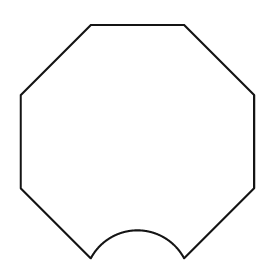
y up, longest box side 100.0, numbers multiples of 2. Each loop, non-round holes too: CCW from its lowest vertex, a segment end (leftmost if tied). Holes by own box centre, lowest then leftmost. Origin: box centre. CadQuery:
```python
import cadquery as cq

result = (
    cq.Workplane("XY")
    .moveTo(-20.0, -50.0)
    .threePointArc((0.0, -38.0), (20.0, -50.0))
    .lineTo(50.0, -20.0)
    .lineTo(50.0, 20.0)
    .lineTo(20.0, 50.0)
    .lineTo(-20.0, 50.0)
    .lineTo(-50.0, 20.0)
    .lineTo(-50.0, -20.0)
    .close()
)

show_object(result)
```